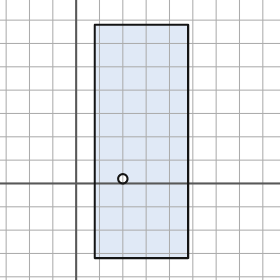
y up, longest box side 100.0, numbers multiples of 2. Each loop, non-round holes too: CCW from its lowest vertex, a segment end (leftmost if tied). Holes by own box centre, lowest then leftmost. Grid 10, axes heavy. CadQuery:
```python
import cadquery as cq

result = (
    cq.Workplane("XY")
    .moveTo(8.0, -32.0)
    .lineTo(48.0, -32.0)
    .lineTo(48.0, 68.0)
    .lineTo(8.0, 68.0)
    .close()
    .moveTo(20.0, 2.0)
    .circle(2.0)
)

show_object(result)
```